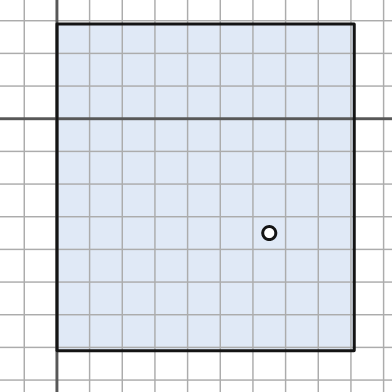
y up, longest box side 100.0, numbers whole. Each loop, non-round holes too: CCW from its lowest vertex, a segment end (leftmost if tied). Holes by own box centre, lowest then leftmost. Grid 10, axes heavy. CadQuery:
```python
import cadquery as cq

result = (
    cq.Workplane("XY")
    .moveTo(0.0, -71.0)
    .lineTo(91.0, -71.0)
    .lineTo(91.0, 29.0)
    .lineTo(0.0, 29.0)
    .close()
    .moveTo(65.0, -35.0)
    .circle(2.0)
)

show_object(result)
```